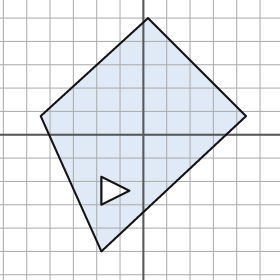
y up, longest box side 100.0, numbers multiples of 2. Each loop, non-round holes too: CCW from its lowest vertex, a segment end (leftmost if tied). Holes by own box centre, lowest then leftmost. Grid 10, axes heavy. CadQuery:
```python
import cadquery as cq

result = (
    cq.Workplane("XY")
    .moveTo(-18.0, -50.0)
    .lineTo(44.0, 8.0)
    .lineTo(2.0, 50.0)
    .lineTo(-44.0, 8.0)
    .close()
    .moveTo(-18.0, -30.0)
    .lineTo(-6.0, -24.0)
    .lineTo(-18.0, -18.0)
    .close()
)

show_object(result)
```